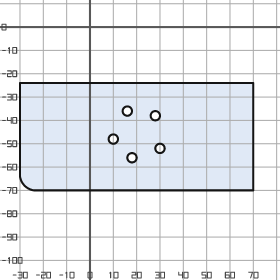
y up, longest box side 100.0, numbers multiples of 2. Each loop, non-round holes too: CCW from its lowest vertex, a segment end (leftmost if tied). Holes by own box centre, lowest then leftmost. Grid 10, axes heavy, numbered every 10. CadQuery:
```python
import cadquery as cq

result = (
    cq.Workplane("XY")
    .moveTo(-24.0, -70.0)
    .lineTo(70.0, -70.0)
    .lineTo(70.0, -24.0)
    .lineTo(-30.0, -24.0)
    .lineTo(-30.0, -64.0)
    .threePointArc((-28.0, -68.0), (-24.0, -70.0))
    .close()
    .moveTo(18.0, -56.0)
    .circle(2.0)
    .moveTo(30.0, -52.0)
    .circle(2.0)
    .moveTo(10.0, -48.0)
    .circle(2.0)
    .moveTo(28.0, -38.0)
    .circle(2.0)
    .moveTo(16.0, -36.0)
    .circle(2.0)
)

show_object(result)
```